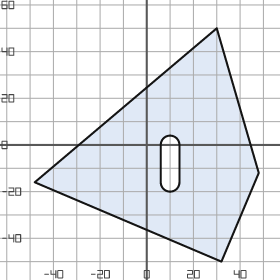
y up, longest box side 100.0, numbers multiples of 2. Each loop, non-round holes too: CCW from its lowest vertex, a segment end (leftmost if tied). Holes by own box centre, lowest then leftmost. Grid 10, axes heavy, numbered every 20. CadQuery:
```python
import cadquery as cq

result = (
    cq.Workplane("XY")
    .moveTo(32.0, -50.0)
    .lineTo(48.0, -12.0)
    .lineTo(30.0, 50.0)
    .lineTo(-48.0, -16.0)
    .close()
    .moveTo(6.0, -16.0)
    .threePointArc((10.0, -20.0), (14.0, -16.0))
    .lineTo(14.0, 0.0)
    .threePointArc((10.0, 4.0), (6.0, 0.0))
    .close()
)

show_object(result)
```